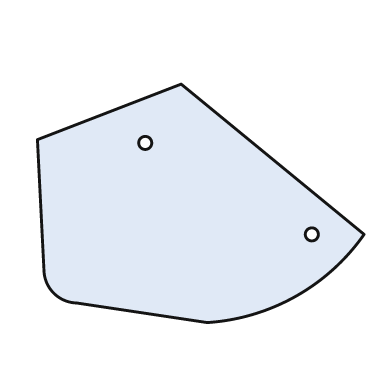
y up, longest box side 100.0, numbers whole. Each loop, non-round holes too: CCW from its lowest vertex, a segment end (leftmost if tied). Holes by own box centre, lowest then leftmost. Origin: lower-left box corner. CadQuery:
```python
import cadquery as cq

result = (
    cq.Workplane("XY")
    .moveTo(52.0, 0.0)
    .threePointArc((79.0, 8.0), (100.0, 27.0))
    .lineTo(44.0, 73.0)
    .lineTo(0.0, 56.0)
    .lineTo(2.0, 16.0)
    .threePointArc((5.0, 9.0), (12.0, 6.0))
    .close()
    .moveTo(84.0, 27.0)
    .circle(2.0)
    .moveTo(33.0, 55.0)
    .circle(2.0)
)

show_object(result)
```